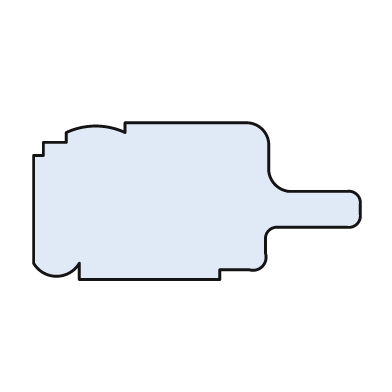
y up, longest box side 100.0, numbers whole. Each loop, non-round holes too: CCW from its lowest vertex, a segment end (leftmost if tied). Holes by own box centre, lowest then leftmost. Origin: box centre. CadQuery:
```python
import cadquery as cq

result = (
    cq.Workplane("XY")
    .moveTo(-36.0, -24.0)
    .lineTo(7.0, -24.0)
    .lineTo(7.0, -21.0)
    .lineTo(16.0, -21.0)
    .threePointArc((20.0, -20.0), (21.0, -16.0))
    .lineTo(21.0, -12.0)
    .threePointArc((22.0, -9.0), (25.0, -8.0))
    .lineTo(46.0, -8.0)
    .threePointArc((49.0, -7.0), (50.0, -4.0))
    .lineTo(50.0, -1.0)
    .threePointArc((49.0, 2.0), (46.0, 3.0))
    .lineTo(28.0, 3.0)
    .threePointArc((24.0, 5.0), (22.0, 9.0))
    .lineTo(22.0, 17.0)
    .threePointArc((20.0, 22.0), (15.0, 24.0))
    .lineTo(-22.0, 24.0)
    .lineTo(-22.0, 21.0)
    .threePointArc((-31.0, 23.0), (-40.0, 21.0))
    .lineTo(-40.0, 18.0)
    .lineTo(-47.0, 18.0)
    .lineTo(-47.0, 14.0)
    .lineTo(-50.0, 14.0)
    .lineTo(-50.0, -19.0)
    .threePointArc((-43.0, -23.0), (-36.0, -19.0))
    .close()
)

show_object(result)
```